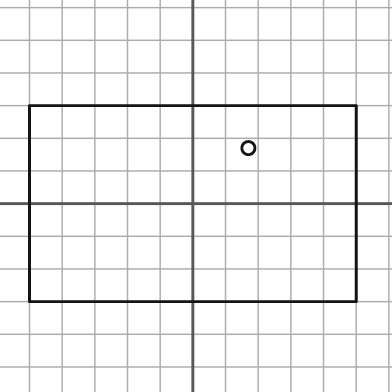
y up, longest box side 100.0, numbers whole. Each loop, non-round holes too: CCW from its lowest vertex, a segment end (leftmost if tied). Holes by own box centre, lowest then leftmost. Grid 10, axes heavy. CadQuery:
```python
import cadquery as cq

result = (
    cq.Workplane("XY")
    .moveTo(-50.0, -30.0)
    .lineTo(50.0, -30.0)
    .lineTo(50.0, 30.0)
    .lineTo(-50.0, 30.0)
    .close()
    .moveTo(17.0, 17.0)
    .circle(2.0)
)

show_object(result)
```